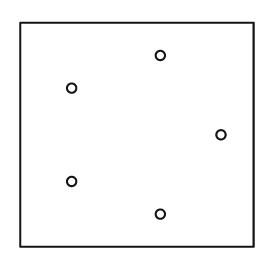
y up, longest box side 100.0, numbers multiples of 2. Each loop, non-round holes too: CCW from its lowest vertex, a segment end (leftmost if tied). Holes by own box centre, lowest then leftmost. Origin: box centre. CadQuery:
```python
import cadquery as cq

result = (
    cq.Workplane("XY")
    .moveTo(-50.0, -48.0)
    .lineTo(50.0, -48.0)
    .lineTo(50.0, 48.0)
    .lineTo(-50.0, 48.0)
    .close()
    .moveTo(10.0, -34.0)
    .circle(2.0)
    .moveTo(-28.0, -20.0)
    .circle(2.0)
    .moveTo(36.0, 0.0)
    .circle(2.0)
    .moveTo(-28.0, 20.0)
    .circle(2.0)
    .moveTo(10.0, 34.0)
    .circle(2.0)
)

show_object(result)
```